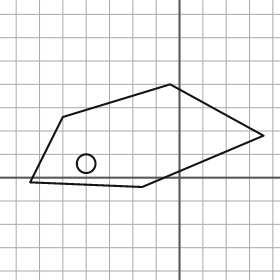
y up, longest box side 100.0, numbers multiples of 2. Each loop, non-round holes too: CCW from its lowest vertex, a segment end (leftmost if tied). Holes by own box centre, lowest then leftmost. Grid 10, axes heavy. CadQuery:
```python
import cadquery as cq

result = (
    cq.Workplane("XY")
    .moveTo(-16.0, -4.0)
    .lineTo(36.0, 18.0)
    .lineTo(-4.0, 40.0)
    .lineTo(-50.0, 26.0)
    .lineTo(-64.0, -2.0)
    .close()
    .moveTo(-40.0, 6.0)
    .circle(4.0)
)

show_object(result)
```